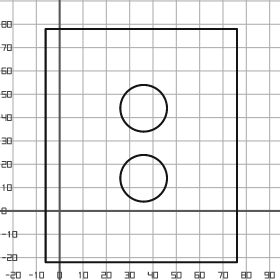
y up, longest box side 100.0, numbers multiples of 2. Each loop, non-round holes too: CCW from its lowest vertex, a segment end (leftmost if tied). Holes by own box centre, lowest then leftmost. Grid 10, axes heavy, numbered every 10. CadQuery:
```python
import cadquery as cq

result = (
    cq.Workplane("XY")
    .moveTo(-6.0, -22.0)
    .lineTo(76.0, -22.0)
    .lineTo(76.0, 78.0)
    .lineTo(-6.0, 78.0)
    .close()
    .moveTo(36.0, 14.0)
    .circle(10.0)
    .moveTo(36.0, 44.0)
    .circle(10.0)
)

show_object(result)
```